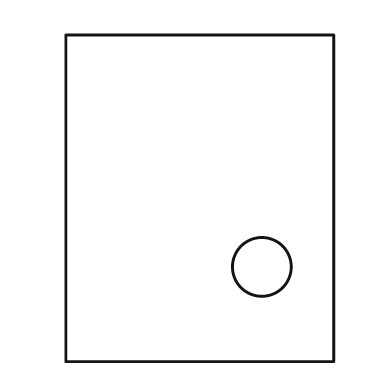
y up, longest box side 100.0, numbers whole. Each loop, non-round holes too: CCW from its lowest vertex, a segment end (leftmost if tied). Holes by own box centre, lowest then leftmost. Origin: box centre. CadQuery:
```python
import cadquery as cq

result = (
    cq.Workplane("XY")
    .moveTo(-41.0, -50.0)
    .lineTo(41.0, -50.0)
    .lineTo(41.0, 50.0)
    .lineTo(-41.0, 50.0)
    .close()
    .moveTo(19.0, -21.0)
    .circle(9.0)
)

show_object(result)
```